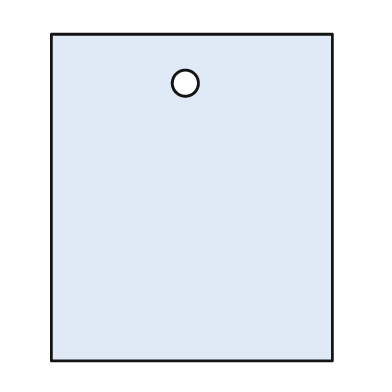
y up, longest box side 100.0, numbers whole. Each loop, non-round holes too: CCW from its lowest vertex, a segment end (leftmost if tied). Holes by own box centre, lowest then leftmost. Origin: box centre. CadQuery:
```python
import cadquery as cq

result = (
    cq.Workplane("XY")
    .moveTo(-43.0, -50.0)
    .lineTo(43.0, -50.0)
    .lineTo(43.0, 50.0)
    .lineTo(-43.0, 50.0)
    .close()
    .moveTo(-2.0, 35.0)
    .circle(4.0)
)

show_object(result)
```